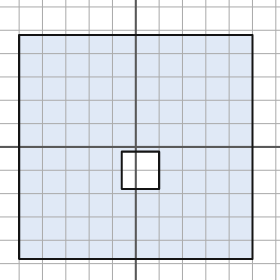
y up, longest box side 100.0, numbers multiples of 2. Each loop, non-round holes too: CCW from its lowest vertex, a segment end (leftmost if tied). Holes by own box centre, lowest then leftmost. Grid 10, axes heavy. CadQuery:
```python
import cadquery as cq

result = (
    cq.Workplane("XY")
    .moveTo(-50.0, -48.0)
    .lineTo(50.0, -48.0)
    .lineTo(50.0, 48.0)
    .lineTo(-50.0, 48.0)
    .close()
    .moveTo(-6.0, -18.0)
    .lineTo(10.0, -18.0)
    .lineTo(10.0, -2.0)
    .lineTo(-6.0, -2.0)
    .close()
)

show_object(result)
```